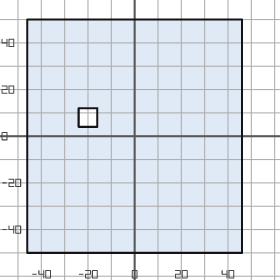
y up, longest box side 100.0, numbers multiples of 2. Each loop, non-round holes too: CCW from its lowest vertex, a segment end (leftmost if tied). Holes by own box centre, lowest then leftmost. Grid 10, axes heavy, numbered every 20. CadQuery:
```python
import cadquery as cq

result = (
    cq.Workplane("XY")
    .moveTo(-46.0, -50.0)
    .lineTo(46.0, -50.0)
    .lineTo(46.0, 50.0)
    .lineTo(-46.0, 50.0)
    .close()
    .moveTo(-24.0, 4.0)
    .lineTo(-16.0, 4.0)
    .lineTo(-16.0, 12.0)
    .lineTo(-24.0, 12.0)
    .close()
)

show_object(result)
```